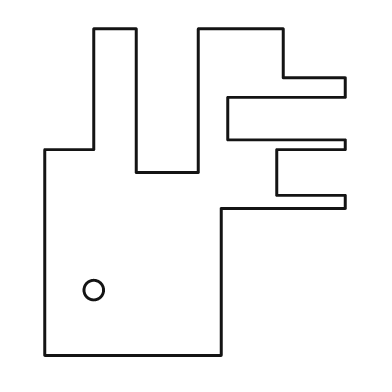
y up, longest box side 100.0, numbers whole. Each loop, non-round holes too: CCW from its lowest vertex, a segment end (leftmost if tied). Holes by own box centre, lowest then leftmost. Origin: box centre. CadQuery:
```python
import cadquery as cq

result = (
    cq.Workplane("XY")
    .moveTo(-46.0, -50.0)
    .lineTo(8.0, -50.0)
    .lineTo(8.0, -5.0)
    .lineTo(46.0, -5.0)
    .lineTo(46.0, -1.0)
    .lineTo(25.0, -1.0)
    .lineTo(25.0, 13.0)
    .lineTo(46.0, 13.0)
    .lineTo(46.0, 16.0)
    .lineTo(10.0, 16.0)
    .lineTo(10.0, 29.0)
    .lineTo(46.0, 29.0)
    .lineTo(46.0, 35.0)
    .lineTo(27.0, 35.0)
    .lineTo(27.0, 50.0)
    .lineTo(1.0, 50.0)
    .lineTo(1.0, 6.0)
    .lineTo(-18.0, 6.0)
    .lineTo(-18.0, 50.0)
    .lineTo(-31.0, 50.0)
    .lineTo(-31.0, 13.0)
    .lineTo(-46.0, 13.0)
    .close()
    .moveTo(-31.0, -30.0)
    .circle(3.0)
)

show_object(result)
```